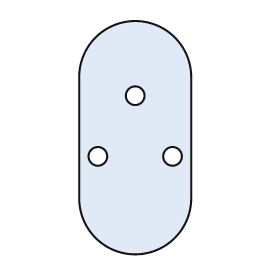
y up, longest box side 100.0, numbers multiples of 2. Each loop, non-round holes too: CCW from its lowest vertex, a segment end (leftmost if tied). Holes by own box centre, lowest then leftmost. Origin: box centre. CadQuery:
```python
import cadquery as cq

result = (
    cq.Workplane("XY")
    .moveTo(-24.0, -26.0)
    .threePointArc((0.0, -50.0), (24.0, -26.0))
    .lineTo(24.0, 26.0)
    .threePointArc((0.0, 50.0), (-24.0, 26.0))
    .close()
    .moveTo(-16.0, -8.0)
    .circle(4.0)
    .moveTo(16.0, -8.0)
    .circle(4.0)
    .moveTo(0.0, 18.0)
    .circle(4.0)
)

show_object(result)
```